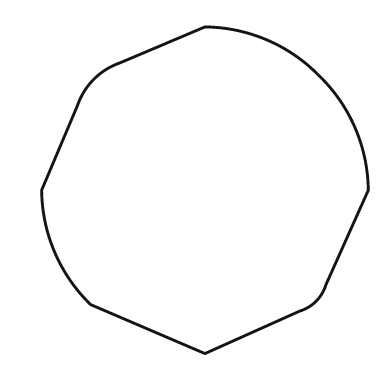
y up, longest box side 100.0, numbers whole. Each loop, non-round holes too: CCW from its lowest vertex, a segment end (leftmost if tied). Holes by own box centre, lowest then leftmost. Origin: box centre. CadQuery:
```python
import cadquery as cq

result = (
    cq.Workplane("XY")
    .moveTo(0.0, -50.0)
    .lineTo(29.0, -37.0)
    .threePointArc((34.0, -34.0), (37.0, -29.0))
    .lineTo(50.0, 0.0)
    .threePointArc((46.0, 19.0), (35.0, 35.0))
    .threePointArc((19.0, 46.0), (0.0, 50.0))
    .lineTo(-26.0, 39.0)
    .threePointArc((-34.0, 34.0), (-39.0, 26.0))
    .lineTo(-50.0, 0.0)
    .threePointArc((-46.0, -19.0), (-35.0, -35.0))
    .close()
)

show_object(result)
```